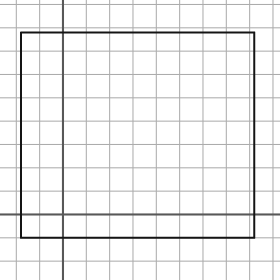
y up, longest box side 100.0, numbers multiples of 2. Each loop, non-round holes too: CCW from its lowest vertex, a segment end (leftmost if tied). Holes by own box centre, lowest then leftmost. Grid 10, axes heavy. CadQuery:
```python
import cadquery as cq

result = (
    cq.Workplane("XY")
    .moveTo(-18.0, -10.0)
    .lineTo(82.0, -10.0)
    .lineTo(82.0, 78.0)
    .lineTo(-18.0, 78.0)
    .close()
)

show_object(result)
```